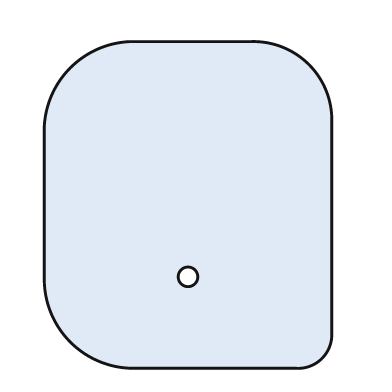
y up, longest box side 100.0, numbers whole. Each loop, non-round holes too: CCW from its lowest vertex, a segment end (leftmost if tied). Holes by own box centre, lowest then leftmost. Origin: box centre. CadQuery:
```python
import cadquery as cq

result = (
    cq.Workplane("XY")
    .moveTo(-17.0, -50.0)
    .lineTo(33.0, -50.0)
    .threePointArc((41.0, -47.0), (44.0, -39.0))
    .lineTo(44.0, 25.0)
    .threePointArc((37.0, 43.0), (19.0, 50.0))
    .lineTo(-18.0, 50.0)
    .threePointArc((-36.0, 42.0), (-44.0, 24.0))
    .lineTo(-44.0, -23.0)
    .threePointArc((-36.0, -42.0), (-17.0, -50.0))
    .close()
    .moveTo(0.0, -22.0)
    .circle(3.0)
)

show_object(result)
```